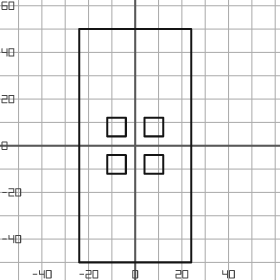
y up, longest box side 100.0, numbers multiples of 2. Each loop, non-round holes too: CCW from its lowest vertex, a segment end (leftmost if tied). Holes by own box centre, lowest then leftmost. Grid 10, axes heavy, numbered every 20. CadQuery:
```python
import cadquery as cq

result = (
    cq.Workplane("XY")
    .moveTo(-24.0, -50.0)
    .lineTo(24.0, -50.0)
    .lineTo(24.0, 50.0)
    .lineTo(-24.0, 50.0)
    .close()
    .moveTo(-12.0, -12.0)
    .lineTo(-4.0, -12.0)
    .lineTo(-4.0, -4.0)
    .lineTo(-12.0, -4.0)
    .close()
    .moveTo(4.0, -12.0)
    .lineTo(12.0, -12.0)
    .lineTo(12.0, -4.0)
    .lineTo(4.0, -4.0)
    .close()
    .moveTo(-12.0, 4.0)
    .lineTo(-4.0, 4.0)
    .lineTo(-4.0, 12.0)
    .lineTo(-12.0, 12.0)
    .close()
    .moveTo(4.0, 4.0)
    .lineTo(12.0, 4.0)
    .lineTo(12.0, 12.0)
    .lineTo(4.0, 12.0)
    .close()
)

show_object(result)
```